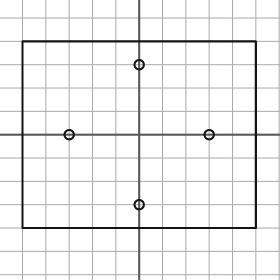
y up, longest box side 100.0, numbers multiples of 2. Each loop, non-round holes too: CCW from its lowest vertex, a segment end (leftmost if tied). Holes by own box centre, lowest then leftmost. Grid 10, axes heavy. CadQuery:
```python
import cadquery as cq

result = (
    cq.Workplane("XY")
    .moveTo(-50.0, -40.0)
    .lineTo(50.0, -40.0)
    .lineTo(50.0, 40.0)
    .lineTo(-50.0, 40.0)
    .close()
    .moveTo(0.0, -30.0)
    .circle(2.0)
    .moveTo(-30.0, 0.0)
    .circle(2.0)
    .moveTo(30.0, 0.0)
    .circle(2.0)
    .moveTo(0.0, 30.0)
    .circle(2.0)
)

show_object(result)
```